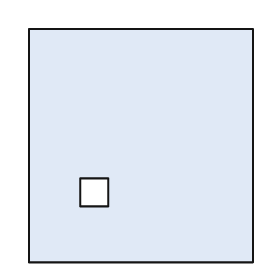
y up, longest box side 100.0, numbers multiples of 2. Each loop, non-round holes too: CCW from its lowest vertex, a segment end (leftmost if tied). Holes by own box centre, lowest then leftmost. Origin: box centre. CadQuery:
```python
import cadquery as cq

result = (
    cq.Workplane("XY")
    .moveTo(-48.0, -50.0)
    .lineTo(48.0, -50.0)
    .lineTo(48.0, 50.0)
    .lineTo(-48.0, 50.0)
    .close()
    .moveTo(-26.0, -26.0)
    .lineTo(-14.0, -26.0)
    .lineTo(-14.0, -14.0)
    .lineTo(-26.0, -14.0)
    .close()
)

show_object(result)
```